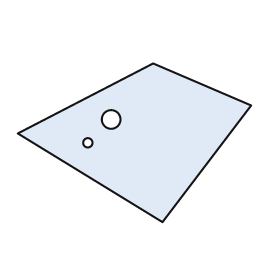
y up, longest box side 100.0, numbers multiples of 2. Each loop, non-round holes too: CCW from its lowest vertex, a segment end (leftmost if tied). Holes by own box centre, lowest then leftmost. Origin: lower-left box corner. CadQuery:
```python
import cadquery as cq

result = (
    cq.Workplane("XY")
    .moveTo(62.0, 0.0)
    .lineTo(100.0, 50.0)
    .lineTo(58.0, 68.0)
    .lineTo(0.0, 38.0)
    .close()
    .moveTo(30.0, 34.0)
    .circle(2.0)
    .moveTo(40.0, 44.0)
    .circle(4.0)
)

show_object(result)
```